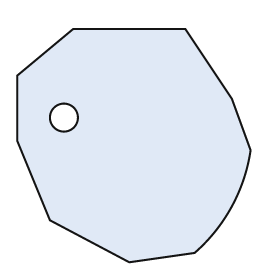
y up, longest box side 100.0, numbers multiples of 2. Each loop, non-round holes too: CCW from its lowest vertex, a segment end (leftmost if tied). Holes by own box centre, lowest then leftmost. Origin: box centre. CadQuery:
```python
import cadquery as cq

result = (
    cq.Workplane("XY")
    .moveTo(-2.0, -50.0)
    .lineTo(26.0, -46.0)
    .threePointArc((42.0, -26.0), (50.0, -2.0))
    .lineTo(42.0, 20.0)
    .lineTo(22.0, 50.0)
    .lineTo(-26.0, 50.0)
    .lineTo(-50.0, 30.0)
    .lineTo(-50.0, 2.0)
    .lineTo(-36.0, -32.0)
    .close()
    .moveTo(-30.0, 12.0)
    .circle(6.0)
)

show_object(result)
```